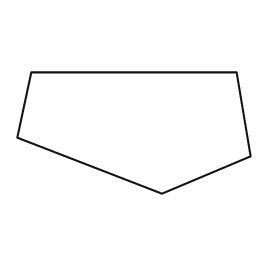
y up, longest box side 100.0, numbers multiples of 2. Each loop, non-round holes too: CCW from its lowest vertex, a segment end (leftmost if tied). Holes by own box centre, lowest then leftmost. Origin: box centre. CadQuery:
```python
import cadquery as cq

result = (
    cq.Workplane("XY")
    .moveTo(12.0, -26.0)
    .lineTo(50.0, -10.0)
    .lineTo(44.0, 26.0)
    .lineTo(-44.0, 26.0)
    .lineTo(-50.0, -2.0)
    .close()
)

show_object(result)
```